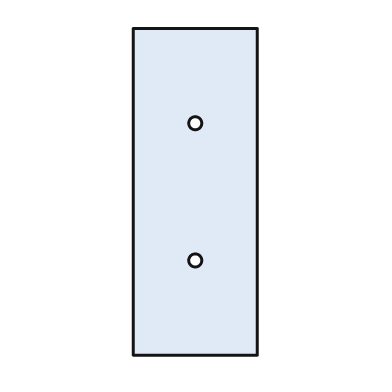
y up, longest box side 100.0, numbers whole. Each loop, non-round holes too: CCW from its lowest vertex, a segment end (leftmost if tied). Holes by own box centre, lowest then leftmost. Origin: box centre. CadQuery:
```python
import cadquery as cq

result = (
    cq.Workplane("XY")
    .moveTo(-19.0, -50.0)
    .lineTo(19.0, -50.0)
    .lineTo(19.0, 50.0)
    .lineTo(-19.0, 50.0)
    .close()
    .moveTo(0.0, -21.0)
    .circle(2.0)
    .moveTo(0.0, 21.0)
    .circle(2.0)
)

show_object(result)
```